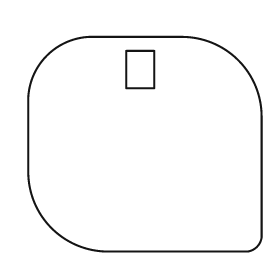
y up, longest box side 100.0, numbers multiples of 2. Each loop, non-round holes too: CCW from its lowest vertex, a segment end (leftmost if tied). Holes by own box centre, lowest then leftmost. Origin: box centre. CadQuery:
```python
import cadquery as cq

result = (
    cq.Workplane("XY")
    .moveTo(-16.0, -46.0)
    .lineTo(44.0, -46.0)
    .threePointArc((48.0, -44.0), (50.0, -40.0))
    .lineTo(50.0, 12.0)
    .threePointArc((40.0, 36.0), (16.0, 46.0))
    .lineTo(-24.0, 46.0)
    .threePointArc((-42.0, 38.0), (-50.0, 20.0))
    .lineTo(-50.0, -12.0)
    .threePointArc((-40.0, -36.0), (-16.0, -46.0))
    .close()
    .moveTo(-8.0, 24.0)
    .lineTo(4.0, 24.0)
    .lineTo(4.0, 40.0)
    .lineTo(-8.0, 40.0)
    .close()
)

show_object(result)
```